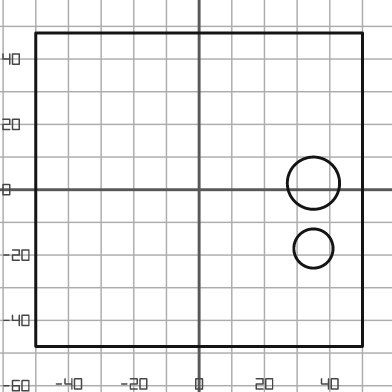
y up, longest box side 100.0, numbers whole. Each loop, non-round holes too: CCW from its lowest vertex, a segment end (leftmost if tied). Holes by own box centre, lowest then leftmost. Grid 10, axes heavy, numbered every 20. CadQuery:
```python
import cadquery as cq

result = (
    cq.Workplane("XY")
    .moveTo(-50.0, -48.0)
    .lineTo(50.0, -48.0)
    .lineTo(50.0, 48.0)
    .lineTo(-50.0, 48.0)
    .close()
    .moveTo(35.0, -18.0)
    .circle(6.0)
    .moveTo(35.0, 2.0)
    .circle(8.0)
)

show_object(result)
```